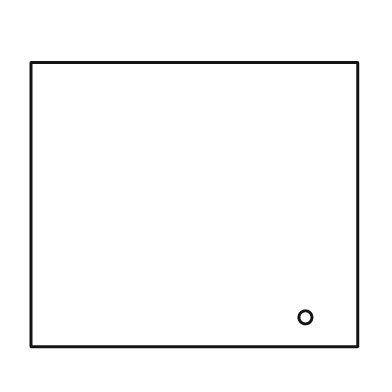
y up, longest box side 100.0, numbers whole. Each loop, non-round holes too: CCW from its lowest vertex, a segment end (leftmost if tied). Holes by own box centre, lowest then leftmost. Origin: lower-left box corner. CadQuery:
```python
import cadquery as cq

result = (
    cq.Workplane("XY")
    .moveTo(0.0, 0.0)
    .lineTo(100.0, 0.0)
    .lineTo(100.0, 87.0)
    .lineTo(0.0, 87.0)
    .close()
    .moveTo(84.0, 9.0)
    .circle(2.0)
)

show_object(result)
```